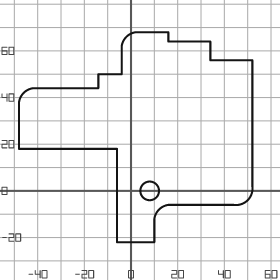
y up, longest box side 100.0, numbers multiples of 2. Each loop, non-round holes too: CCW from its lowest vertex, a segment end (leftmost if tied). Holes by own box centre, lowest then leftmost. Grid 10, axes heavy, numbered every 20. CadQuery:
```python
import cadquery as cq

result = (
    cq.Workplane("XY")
    .moveTo(-6.0, -22.0)
    .lineTo(10.0, -22.0)
    .lineTo(10.0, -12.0)
    .threePointArc((12.0, -8.0), (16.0, -6.0))
    .lineTo(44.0, -6.0)
    .threePointArc((50.0, -4.0), (52.0, 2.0))
    .lineTo(52.0, 56.0)
    .lineTo(34.0, 56.0)
    .lineTo(34.0, 64.0)
    .lineTo(16.0, 64.0)
    .lineTo(16.0, 68.0)
    .lineTo(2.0, 68.0)
    .threePointArc((-2.0, 66.0), (-4.0, 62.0))
    .lineTo(-4.0, 50.0)
    .lineTo(-14.0, 50.0)
    .lineTo(-14.0, 44.0)
    .lineTo(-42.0, 44.0)
    .threePointArc((-46.0, 42.0), (-48.0, 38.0))
    .lineTo(-48.0, 18.0)
    .lineTo(-6.0, 18.0)
    .close()
    .moveTo(8.0, 0.0)
    .circle(4.0)
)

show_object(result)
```